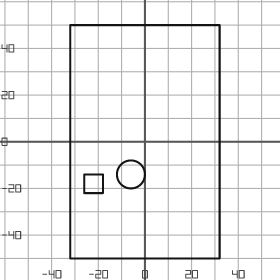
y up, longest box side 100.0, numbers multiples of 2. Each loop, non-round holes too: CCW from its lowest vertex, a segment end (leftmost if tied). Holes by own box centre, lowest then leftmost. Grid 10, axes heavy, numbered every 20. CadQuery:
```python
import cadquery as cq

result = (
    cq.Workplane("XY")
    .moveTo(-32.0, -50.0)
    .lineTo(32.0, -50.0)
    .lineTo(32.0, 50.0)
    .lineTo(-32.0, 50.0)
    .close()
    .moveTo(-26.0, -22.0)
    .lineTo(-18.0, -22.0)
    .lineTo(-18.0, -14.0)
    .lineTo(-26.0, -14.0)
    .close()
    .moveTo(-6.0, -14.0)
    .circle(6.0)
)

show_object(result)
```